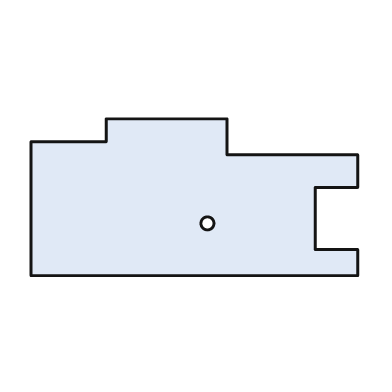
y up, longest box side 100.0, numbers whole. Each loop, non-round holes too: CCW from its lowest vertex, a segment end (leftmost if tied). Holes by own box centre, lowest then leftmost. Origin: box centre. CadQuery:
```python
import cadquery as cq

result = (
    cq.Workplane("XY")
    .moveTo(-50.0, -24.0)
    .lineTo(50.0, -24.0)
    .lineTo(50.0, -16.0)
    .lineTo(37.0, -16.0)
    .lineTo(37.0, 3.0)
    .lineTo(50.0, 3.0)
    .lineTo(50.0, 13.0)
    .lineTo(10.0, 13.0)
    .lineTo(10.0, 24.0)
    .lineTo(-27.0, 24.0)
    .lineTo(-27.0, 17.0)
    .lineTo(-50.0, 17.0)
    .close()
    .moveTo(4.0, -8.0)
    .circle(2.0)
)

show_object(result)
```